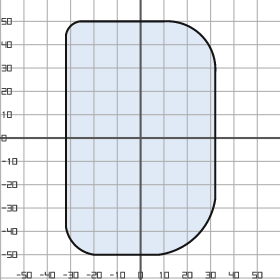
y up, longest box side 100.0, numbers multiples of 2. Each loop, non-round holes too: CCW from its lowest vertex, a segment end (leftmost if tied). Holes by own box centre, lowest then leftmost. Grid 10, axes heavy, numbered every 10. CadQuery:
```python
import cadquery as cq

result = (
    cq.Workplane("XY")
    .moveTo(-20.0, -50.0)
    .lineTo(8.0, -50.0)
    .threePointArc((24.0, -42.0), (32.0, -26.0))
    .lineTo(32.0, 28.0)
    .threePointArc((26.0, 44.0), (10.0, 50.0))
    .lineTo(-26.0, 50.0)
    .threePointArc((-30.0, 48.0), (-32.0, 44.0))
    .lineTo(-32.0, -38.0)
    .threePointArc((-28.0, -46.0), (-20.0, -50.0))
    .close()
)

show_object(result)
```